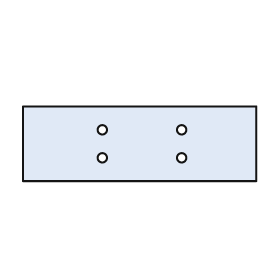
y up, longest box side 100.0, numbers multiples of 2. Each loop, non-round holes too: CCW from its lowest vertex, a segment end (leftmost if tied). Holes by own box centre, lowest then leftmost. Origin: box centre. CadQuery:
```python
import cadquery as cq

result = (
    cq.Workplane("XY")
    .moveTo(-50.0, -16.0)
    .lineTo(50.0, -16.0)
    .lineTo(50.0, 16.0)
    .lineTo(-50.0, 16.0)
    .close()
    .moveTo(-16.0, -6.0)
    .circle(2.0)
    .moveTo(18.0, -6.0)
    .circle(2.0)
    .moveTo(-16.0, 6.0)
    .circle(2.0)
    .moveTo(18.0, 6.0)
    .circle(2.0)
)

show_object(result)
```